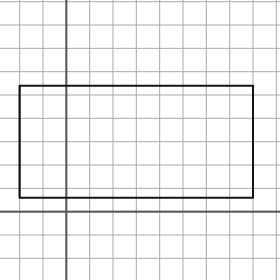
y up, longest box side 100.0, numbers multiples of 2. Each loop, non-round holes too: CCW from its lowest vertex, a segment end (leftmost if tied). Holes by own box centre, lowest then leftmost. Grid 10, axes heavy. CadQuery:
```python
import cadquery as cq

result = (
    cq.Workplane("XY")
    .moveTo(-20.0, 6.0)
    .lineTo(80.0, 6.0)
    .lineTo(80.0, 54.0)
    .lineTo(-20.0, 54.0)
    .close()
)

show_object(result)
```